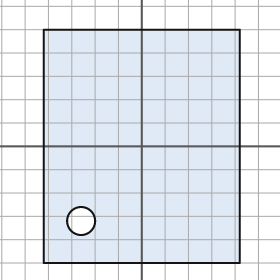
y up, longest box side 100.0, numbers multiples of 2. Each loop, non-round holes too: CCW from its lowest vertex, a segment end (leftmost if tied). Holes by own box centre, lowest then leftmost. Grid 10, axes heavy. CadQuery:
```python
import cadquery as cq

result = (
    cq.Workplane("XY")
    .moveTo(-42.0, -50.0)
    .lineTo(42.0, -50.0)
    .lineTo(42.0, 50.0)
    .lineTo(-42.0, 50.0)
    .close()
    .moveTo(-26.0, -32.0)
    .circle(6.0)
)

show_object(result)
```